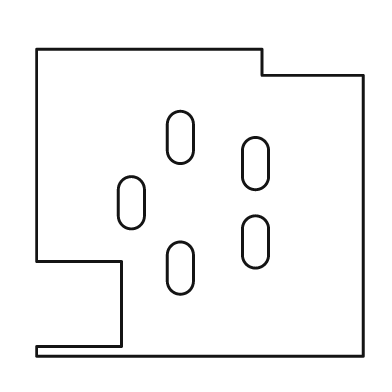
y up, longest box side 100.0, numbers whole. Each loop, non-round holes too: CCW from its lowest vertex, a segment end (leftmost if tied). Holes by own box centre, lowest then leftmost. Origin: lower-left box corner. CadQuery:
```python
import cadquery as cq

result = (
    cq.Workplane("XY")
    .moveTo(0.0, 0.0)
    .lineTo(100.0, 0.0)
    .lineTo(100.0, 86.0)
    .lineTo(69.0, 86.0)
    .lineTo(69.0, 94.0)
    .lineTo(0.0, 94.0)
    .lineTo(0.0, 29.0)
    .lineTo(26.0, 29.0)
    .lineTo(26.0, 3.0)
    .lineTo(0.0, 3.0)
    .close()
    .moveTo(40.0, 23.0)
    .threePointArc((44.0, 19.0), (48.0, 23.0))
    .lineTo(48.0, 31.0)
    .threePointArc((44.0, 35.0), (40.0, 31.0))
    .close()
    .moveTo(63.0, 31.0)
    .threePointArc((67.0, 27.0), (71.0, 31.0))
    .lineTo(71.0, 39.0)
    .threePointArc((67.0, 43.0), (63.0, 39.0))
    .close()
    .moveTo(25.0, 43.0)
    .threePointArc((29.0, 39.0), (33.0, 43.0))
    .lineTo(33.0, 51.0)
    .threePointArc((29.0, 55.0), (25.0, 51.0))
    .close()
    .moveTo(63.0, 55.0)
    .threePointArc((67.0, 51.0), (71.0, 55.0))
    .lineTo(71.0, 63.0)
    .threePointArc((67.0, 67.0), (63.0, 63.0))
    .close()
    .moveTo(40.0, 63.0)
    .threePointArc((44.0, 59.0), (48.0, 63.0))
    .lineTo(48.0, 71.0)
    .threePointArc((44.0, 75.0), (40.0, 71.0))
    .close()
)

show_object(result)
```